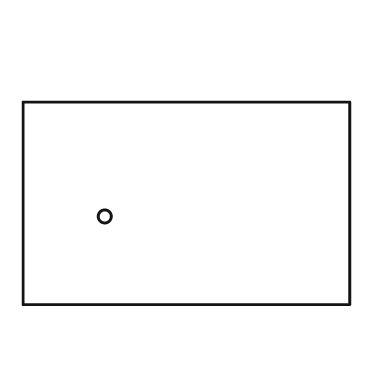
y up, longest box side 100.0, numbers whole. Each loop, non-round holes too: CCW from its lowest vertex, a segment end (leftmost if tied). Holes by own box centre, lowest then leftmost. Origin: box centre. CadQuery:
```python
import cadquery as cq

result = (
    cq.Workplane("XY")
    .moveTo(-50.0, -31.0)
    .lineTo(50.0, -31.0)
    .lineTo(50.0, 31.0)
    .lineTo(-50.0, 31.0)
    .close()
    .moveTo(-25.0, -4.0)
    .circle(2.0)
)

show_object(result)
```